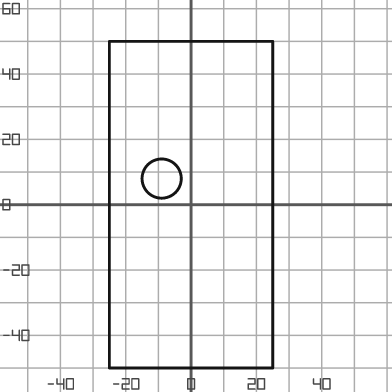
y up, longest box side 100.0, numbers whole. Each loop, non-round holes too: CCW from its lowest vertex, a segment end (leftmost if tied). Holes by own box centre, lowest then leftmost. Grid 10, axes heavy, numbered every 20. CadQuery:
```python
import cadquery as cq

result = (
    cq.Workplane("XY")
    .moveTo(-25.0, -50.0)
    .lineTo(25.0, -50.0)
    .lineTo(25.0, 50.0)
    .lineTo(-25.0, 50.0)
    .close()
    .moveTo(-9.0, 8.0)
    .circle(6.0)
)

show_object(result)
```